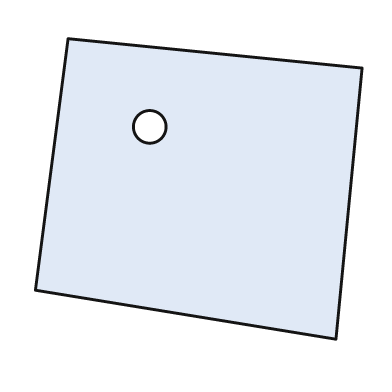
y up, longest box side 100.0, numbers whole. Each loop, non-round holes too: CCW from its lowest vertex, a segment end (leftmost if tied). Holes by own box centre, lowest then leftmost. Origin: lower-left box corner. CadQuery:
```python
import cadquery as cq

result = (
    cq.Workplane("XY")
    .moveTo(92.0, 0.0)
    .lineTo(100.0, 83.0)
    .lineTo(10.0, 92.0)
    .lineTo(0.0, 15.0)
    .close()
    .moveTo(35.0, 65.0)
    .circle(5.0)
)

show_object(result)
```